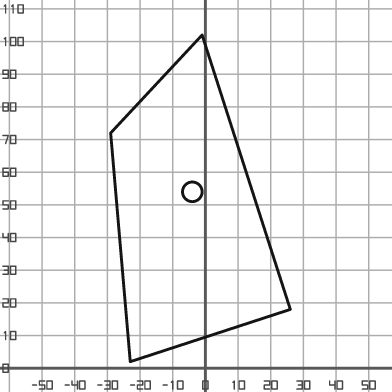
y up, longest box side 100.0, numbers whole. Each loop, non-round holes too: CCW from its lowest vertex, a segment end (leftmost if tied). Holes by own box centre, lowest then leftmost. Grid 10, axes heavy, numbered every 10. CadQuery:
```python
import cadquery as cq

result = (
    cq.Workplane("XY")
    .moveTo(-23.0, 2.0)
    .lineTo(26.0, 18.0)
    .lineTo(-1.0, 102.0)
    .lineTo(-29.0, 72.0)
    .close()
    .moveTo(-4.0, 54.0)
    .circle(3.0)
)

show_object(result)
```